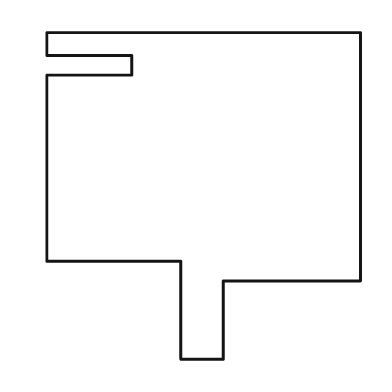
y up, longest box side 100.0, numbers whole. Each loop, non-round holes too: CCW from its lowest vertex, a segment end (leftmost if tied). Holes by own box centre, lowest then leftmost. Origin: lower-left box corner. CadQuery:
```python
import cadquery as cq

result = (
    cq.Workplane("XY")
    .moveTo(41.0, 0.0)
    .lineTo(54.0, 0.0)
    .lineTo(54.0, 24.0)
    .lineTo(96.0, 24.0)
    .lineTo(96.0, 100.0)
    .lineTo(0.0, 100.0)
    .lineTo(0.0, 93.0)
    .lineTo(26.0, 93.0)
    .lineTo(26.0, 87.0)
    .lineTo(0.0, 87.0)
    .lineTo(0.0, 30.0)
    .lineTo(41.0, 30.0)
    .close()
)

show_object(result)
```